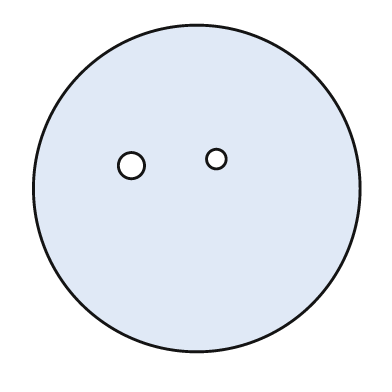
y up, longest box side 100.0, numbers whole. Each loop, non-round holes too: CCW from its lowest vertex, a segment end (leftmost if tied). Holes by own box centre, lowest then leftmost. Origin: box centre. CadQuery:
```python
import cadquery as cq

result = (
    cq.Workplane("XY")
    .moveTo(0.0, 0.0)
    .circle(50.0)
    .moveTo(-20.0, 7.0)
    .circle(4.0)
    .moveTo(6.0, 9.0)
    .circle(3.0)
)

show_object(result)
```